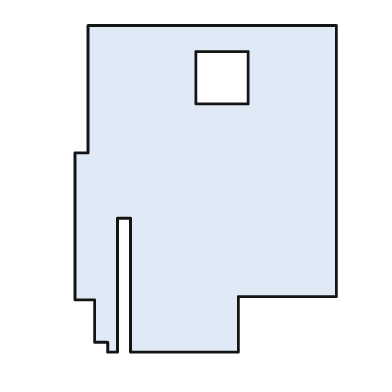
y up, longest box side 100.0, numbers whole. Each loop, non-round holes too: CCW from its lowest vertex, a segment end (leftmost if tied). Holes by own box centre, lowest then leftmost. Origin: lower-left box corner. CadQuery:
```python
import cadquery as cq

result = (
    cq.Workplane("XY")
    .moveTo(10.0, 0.0)
    .lineTo(13.0, 0.0)
    .lineTo(13.0, 41.0)
    .lineTo(17.0, 41.0)
    .lineTo(17.0, 0.0)
    .lineTo(50.0, 0.0)
    .lineTo(50.0, 17.0)
    .lineTo(80.0, 17.0)
    .lineTo(80.0, 100.0)
    .lineTo(4.0, 100.0)
    .lineTo(4.0, 61.0)
    .lineTo(0.0, 61.0)
    .lineTo(0.0, 16.0)
    .lineTo(6.0, 16.0)
    .lineTo(6.0, 3.0)
    .lineTo(10.0, 3.0)
    .close()
    .moveTo(37.0, 76.0)
    .lineTo(53.0, 76.0)
    .lineTo(53.0, 92.0)
    .lineTo(37.0, 92.0)
    .close()
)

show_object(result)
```